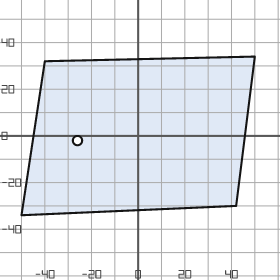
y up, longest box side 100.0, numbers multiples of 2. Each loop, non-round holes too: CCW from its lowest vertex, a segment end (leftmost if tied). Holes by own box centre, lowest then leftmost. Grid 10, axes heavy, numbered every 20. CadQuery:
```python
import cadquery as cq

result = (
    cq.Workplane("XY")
    .moveTo(-50.0, -34.0)
    .lineTo(42.0, -30.0)
    .lineTo(50.0, 34.0)
    .lineTo(-40.0, 32.0)
    .close()
    .moveTo(-26.0, -2.0)
    .circle(2.0)
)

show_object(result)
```